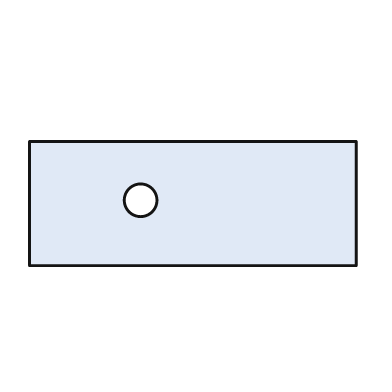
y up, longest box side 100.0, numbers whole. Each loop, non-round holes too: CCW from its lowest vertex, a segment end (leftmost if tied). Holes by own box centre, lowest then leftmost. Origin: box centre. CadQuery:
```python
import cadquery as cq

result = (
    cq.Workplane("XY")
    .moveTo(-50.0, -19.0)
    .lineTo(50.0, -19.0)
    .lineTo(50.0, 19.0)
    .lineTo(-50.0, 19.0)
    .close()
    .moveTo(-16.0, 1.0)
    .circle(5.0)
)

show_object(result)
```